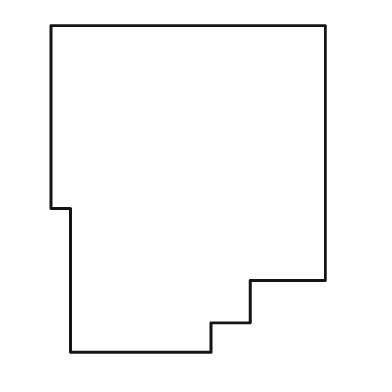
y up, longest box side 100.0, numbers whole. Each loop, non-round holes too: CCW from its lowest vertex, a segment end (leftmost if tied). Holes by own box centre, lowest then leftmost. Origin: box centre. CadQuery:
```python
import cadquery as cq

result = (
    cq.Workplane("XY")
    .moveTo(-36.0, -50.0)
    .lineTo(7.0, -50.0)
    .lineTo(7.0, -41.0)
    .lineTo(19.0, -41.0)
    .lineTo(19.0, -28.0)
    .lineTo(42.0, -28.0)
    .lineTo(42.0, 50.0)
    .lineTo(-42.0, 50.0)
    .lineTo(-42.0, -6.0)
    .lineTo(-36.0, -6.0)
    .close()
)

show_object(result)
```